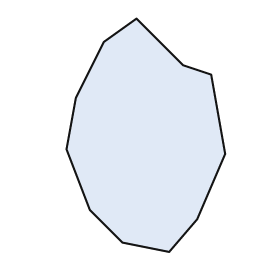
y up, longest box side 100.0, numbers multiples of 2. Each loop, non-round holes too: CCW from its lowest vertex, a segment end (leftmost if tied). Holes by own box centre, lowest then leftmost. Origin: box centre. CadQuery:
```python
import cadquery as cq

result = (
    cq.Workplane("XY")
    .moveTo(10.0, -50.0)
    .lineTo(22.0, -36.0)
    .lineTo(34.0, -8.0)
    .lineTo(28.0, 26.0)
    .lineTo(16.0, 30.0)
    .lineTo(-4.0, 50.0)
    .lineTo(-18.0, 40.0)
    .lineTo(-30.0, 16.0)
    .lineTo(-34.0, -6.0)
    .lineTo(-24.0, -32.0)
    .lineTo(-10.0, -46.0)
    .close()
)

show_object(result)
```